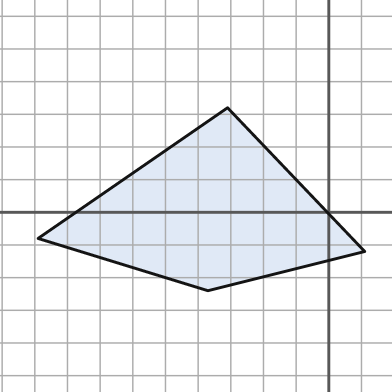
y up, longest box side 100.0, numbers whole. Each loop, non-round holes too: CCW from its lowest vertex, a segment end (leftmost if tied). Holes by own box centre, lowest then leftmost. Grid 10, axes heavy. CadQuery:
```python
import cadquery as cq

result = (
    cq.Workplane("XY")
    .moveTo(-37.0, -24.0)
    .lineTo(11.0, -12.0)
    .lineTo(-31.0, 32.0)
    .lineTo(-89.0, -8.0)
    .close()
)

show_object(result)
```